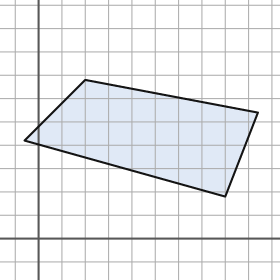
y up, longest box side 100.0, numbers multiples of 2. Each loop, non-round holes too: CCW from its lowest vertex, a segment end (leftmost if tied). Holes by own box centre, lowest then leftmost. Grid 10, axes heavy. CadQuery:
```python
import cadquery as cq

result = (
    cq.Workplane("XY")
    .moveTo(80.0, 18.0)
    .lineTo(94.0, 54.0)
    .lineTo(20.0, 68.0)
    .lineTo(-6.0, 42.0)
    .close()
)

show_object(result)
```